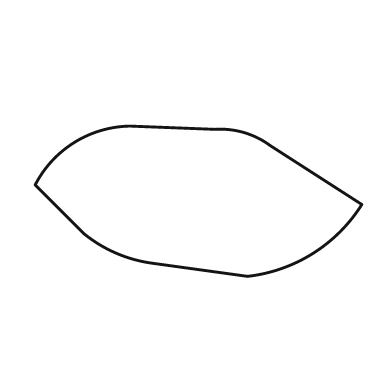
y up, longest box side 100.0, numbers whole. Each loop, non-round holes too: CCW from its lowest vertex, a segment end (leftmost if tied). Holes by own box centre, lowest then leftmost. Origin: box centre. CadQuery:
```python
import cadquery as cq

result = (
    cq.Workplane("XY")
    .moveTo(15.0, -23.0)
    .threePointArc((35.0, -16.0), (50.0, -1.0))
    .lineTo(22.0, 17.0)
    .threePointArc((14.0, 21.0), (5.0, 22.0))
    .lineTo(-21.0, 23.0)
    .threePointArc((-38.0, 18.0), (-50.0, 5.0))
    .lineTo(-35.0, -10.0)
    .threePointArc((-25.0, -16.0), (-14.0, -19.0))
    .close()
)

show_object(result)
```